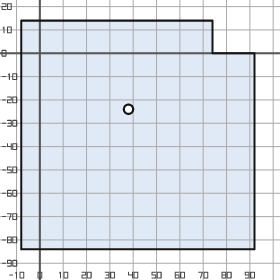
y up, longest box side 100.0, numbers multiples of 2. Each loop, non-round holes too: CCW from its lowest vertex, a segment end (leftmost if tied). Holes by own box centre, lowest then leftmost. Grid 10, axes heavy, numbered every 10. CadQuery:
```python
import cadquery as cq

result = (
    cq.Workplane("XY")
    .moveTo(-8.0, -84.0)
    .lineTo(92.0, -84.0)
    .lineTo(92.0, 0.0)
    .lineTo(74.0, 0.0)
    .lineTo(74.0, 14.0)
    .lineTo(-8.0, 14.0)
    .close()
    .moveTo(38.0, -24.0)
    .circle(2.0)
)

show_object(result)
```